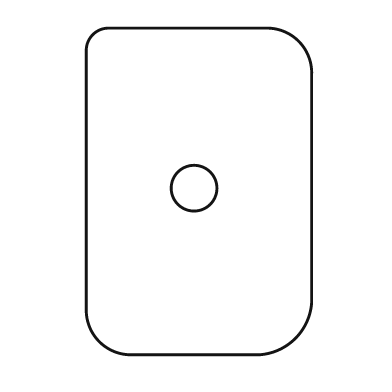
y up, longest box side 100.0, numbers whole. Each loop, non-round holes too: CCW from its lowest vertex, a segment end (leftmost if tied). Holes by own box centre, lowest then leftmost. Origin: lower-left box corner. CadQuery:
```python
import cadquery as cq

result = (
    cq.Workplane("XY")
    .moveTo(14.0, 0.0)
    .lineTo(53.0, 0.0)
    .threePointArc((64.0, 5.0), (69.0, 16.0))
    .lineTo(69.0, 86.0)
    .threePointArc((65.0, 96.0), (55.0, 100.0))
    .lineTo(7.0, 100.0)
    .threePointArc((2.0, 98.0), (0.0, 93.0))
    .lineTo(0.0, 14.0)
    .threePointArc((4.0, 4.0), (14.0, 0.0))
    .close()
    .moveTo(33.0, 51.0)
    .circle(7.0)
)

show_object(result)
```